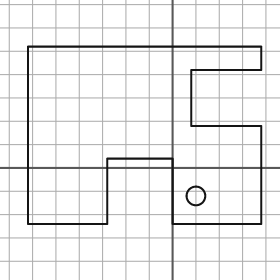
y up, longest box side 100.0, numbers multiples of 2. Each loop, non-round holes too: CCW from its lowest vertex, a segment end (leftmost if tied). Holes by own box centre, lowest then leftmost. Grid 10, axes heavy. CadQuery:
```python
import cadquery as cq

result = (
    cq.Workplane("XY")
    .moveTo(-62.0, -24.0)
    .lineTo(-28.0, -24.0)
    .lineTo(-28.0, 4.0)
    .lineTo(0.0, 4.0)
    .lineTo(0.0, -24.0)
    .lineTo(38.0, -24.0)
    .lineTo(38.0, 18.0)
    .lineTo(8.0, 18.0)
    .lineTo(8.0, 42.0)
    .lineTo(38.0, 42.0)
    .lineTo(38.0, 52.0)
    .lineTo(-62.0, 52.0)
    .close()
    .moveTo(10.0, -12.0)
    .circle(4.0)
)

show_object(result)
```